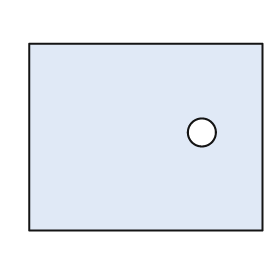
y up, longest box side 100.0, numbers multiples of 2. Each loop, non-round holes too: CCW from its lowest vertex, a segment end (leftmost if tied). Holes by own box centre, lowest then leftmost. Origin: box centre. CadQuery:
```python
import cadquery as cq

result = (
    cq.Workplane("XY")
    .moveTo(-50.0, -40.0)
    .lineTo(50.0, -40.0)
    .lineTo(50.0, 40.0)
    .lineTo(-50.0, 40.0)
    .close()
    .moveTo(24.0, 2.0)
    .circle(6.0)
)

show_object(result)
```